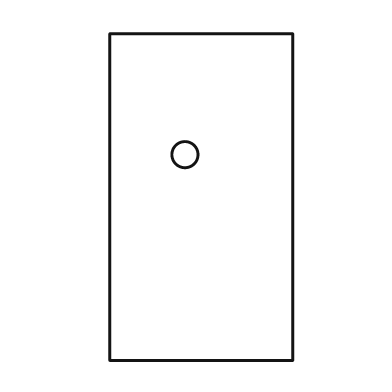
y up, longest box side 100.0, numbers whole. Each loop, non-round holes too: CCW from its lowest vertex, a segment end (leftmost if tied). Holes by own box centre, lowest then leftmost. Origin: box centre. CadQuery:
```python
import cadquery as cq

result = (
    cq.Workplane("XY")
    .moveTo(-28.0, -50.0)
    .lineTo(28.0, -50.0)
    .lineTo(28.0, 50.0)
    .lineTo(-28.0, 50.0)
    .close()
    .moveTo(-5.0, 13.0)
    .circle(4.0)
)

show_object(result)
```